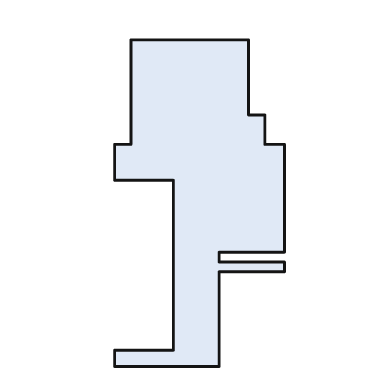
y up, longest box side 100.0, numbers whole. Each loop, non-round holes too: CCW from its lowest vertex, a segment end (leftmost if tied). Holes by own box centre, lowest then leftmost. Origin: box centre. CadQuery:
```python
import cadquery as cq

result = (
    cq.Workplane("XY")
    .moveTo(-26.0, -50.0)
    .lineTo(6.0, -50.0)
    .lineTo(6.0, -21.0)
    .lineTo(26.0, -21.0)
    .lineTo(26.0, -18.0)
    .lineTo(6.0, -18.0)
    .lineTo(6.0, -15.0)
    .lineTo(26.0, -15.0)
    .lineTo(26.0, 18.0)
    .lineTo(20.0, 18.0)
    .lineTo(20.0, 27.0)
    .lineTo(15.0, 27.0)
    .lineTo(15.0, 50.0)
    .lineTo(-21.0, 50.0)
    .lineTo(-21.0, 18.0)
    .lineTo(-26.0, 18.0)
    .lineTo(-26.0, 7.0)
    .lineTo(-8.0, 7.0)
    .lineTo(-8.0, -45.0)
    .lineTo(-26.0, -45.0)
    .close()
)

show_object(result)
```